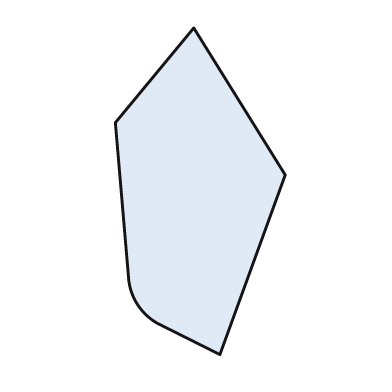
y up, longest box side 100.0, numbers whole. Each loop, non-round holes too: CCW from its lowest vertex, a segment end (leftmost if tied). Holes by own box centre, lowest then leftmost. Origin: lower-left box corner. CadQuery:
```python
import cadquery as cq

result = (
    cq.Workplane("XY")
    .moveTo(32.0, 0.0)
    .lineTo(52.0, 55.0)
    .lineTo(24.0, 100.0)
    .lineTo(0.0, 71.0)
    .lineTo(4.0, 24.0)
    .threePointArc((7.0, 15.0), (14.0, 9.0))
    .close()
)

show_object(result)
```